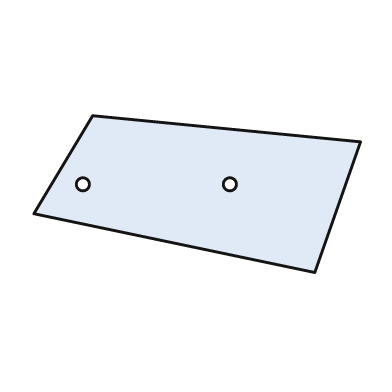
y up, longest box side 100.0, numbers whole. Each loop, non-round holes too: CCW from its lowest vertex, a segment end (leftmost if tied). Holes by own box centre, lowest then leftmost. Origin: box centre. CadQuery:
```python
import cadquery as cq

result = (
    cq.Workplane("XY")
    .moveTo(36.0, -24.0)
    .lineTo(50.0, 16.0)
    .lineTo(-32.0, 24.0)
    .lineTo(-50.0, -6.0)
    .close()
    .moveTo(-35.0, 3.0)
    .circle(2.0)
    .moveTo(10.0, 3.0)
    .circle(2.0)
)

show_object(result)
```